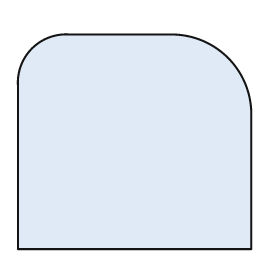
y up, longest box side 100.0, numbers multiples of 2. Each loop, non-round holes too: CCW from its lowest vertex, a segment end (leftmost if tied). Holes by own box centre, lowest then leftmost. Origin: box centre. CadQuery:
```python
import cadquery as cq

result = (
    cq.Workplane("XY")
    .moveTo(-50.0, -46.0)
    .lineTo(50.0, -46.0)
    .lineTo(50.0, 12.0)
    .threePointArc((40.0, 36.0), (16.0, 46.0))
    .lineTo(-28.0, 46.0)
    .threePointArc((-44.0, 40.0), (-50.0, 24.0))
    .close()
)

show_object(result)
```